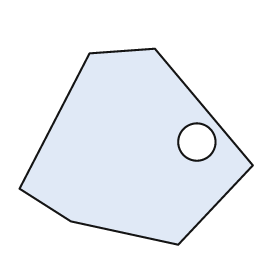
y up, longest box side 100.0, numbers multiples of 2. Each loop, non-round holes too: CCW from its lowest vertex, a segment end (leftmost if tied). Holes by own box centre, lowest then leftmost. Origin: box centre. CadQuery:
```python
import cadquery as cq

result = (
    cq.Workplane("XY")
    .moveTo(18.0, -42.0)
    .lineTo(50.0, -8.0)
    .lineTo(8.0, 42.0)
    .lineTo(-20.0, 40.0)
    .lineTo(-50.0, -18.0)
    .lineTo(-28.0, -32.0)
    .close()
    .moveTo(26.0, 2.0)
    .circle(8.0)
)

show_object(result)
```